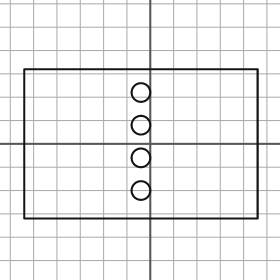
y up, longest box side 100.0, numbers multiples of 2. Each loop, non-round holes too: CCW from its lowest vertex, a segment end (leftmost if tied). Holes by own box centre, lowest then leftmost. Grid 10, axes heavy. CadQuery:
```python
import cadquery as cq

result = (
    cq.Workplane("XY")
    .moveTo(-54.0, -32.0)
    .lineTo(46.0, -32.0)
    .lineTo(46.0, 32.0)
    .lineTo(-54.0, 32.0)
    .close()
    .moveTo(-4.0, -20.0)
    .circle(4.0)
    .moveTo(-4.0, -6.0)
    .circle(4.0)
    .moveTo(-4.0, 8.0)
    .circle(4.0)
    .moveTo(-4.0, 22.0)
    .circle(4.0)
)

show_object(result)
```